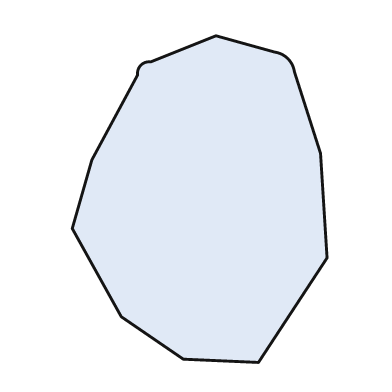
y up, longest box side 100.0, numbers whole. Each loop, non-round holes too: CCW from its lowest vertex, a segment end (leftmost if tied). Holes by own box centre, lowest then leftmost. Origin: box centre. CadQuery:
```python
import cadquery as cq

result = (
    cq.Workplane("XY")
    .moveTo(18.0, -50.0)
    .lineTo(39.0, -18.0)
    .lineTo(37.0, 14.0)
    .lineTo(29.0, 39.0)
    .threePointArc((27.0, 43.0), (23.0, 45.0))
    .lineTo(5.0, 50.0)
    .lineTo(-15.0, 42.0)
    .threePointArc((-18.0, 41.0), (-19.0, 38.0))
    .lineTo(-33.0, 12.0)
    .lineTo(-39.0, -9.0)
    .lineTo(-24.0, -36.0)
    .lineTo(-5.0, -49.0)
    .close()
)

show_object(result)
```